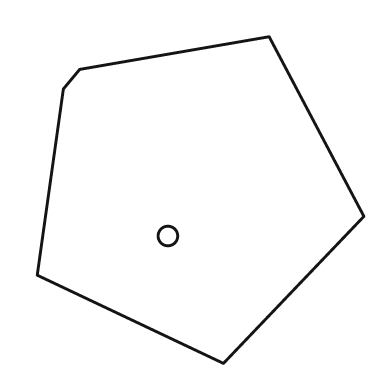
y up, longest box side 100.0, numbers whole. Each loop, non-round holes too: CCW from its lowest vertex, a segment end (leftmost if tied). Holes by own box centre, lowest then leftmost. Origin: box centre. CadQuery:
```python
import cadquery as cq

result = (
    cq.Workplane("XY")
    .moveTo(7.0, -50.0)
    .lineTo(50.0, -5.0)
    .lineTo(21.0, 50.0)
    .lineTo(-37.0, 40.0)
    .lineTo(-42.0, 34.0)
    .lineTo(-50.0, -23.0)
    .close()
    .moveTo(-10.0, -11.0)
    .circle(3.0)
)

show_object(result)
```